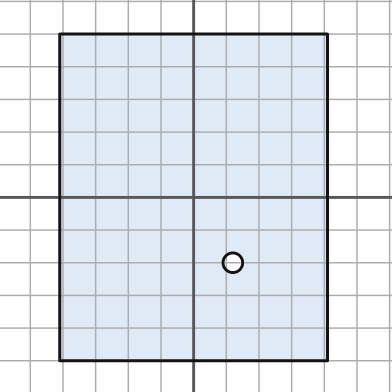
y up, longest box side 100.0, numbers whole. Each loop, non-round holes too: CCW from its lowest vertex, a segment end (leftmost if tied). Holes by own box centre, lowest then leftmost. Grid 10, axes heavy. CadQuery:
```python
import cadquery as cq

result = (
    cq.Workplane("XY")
    .moveTo(-41.0, -50.0)
    .lineTo(41.0, -50.0)
    .lineTo(41.0, 50.0)
    .lineTo(-41.0, 50.0)
    .close()
    .moveTo(12.0, -20.0)
    .circle(3.0)
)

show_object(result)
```